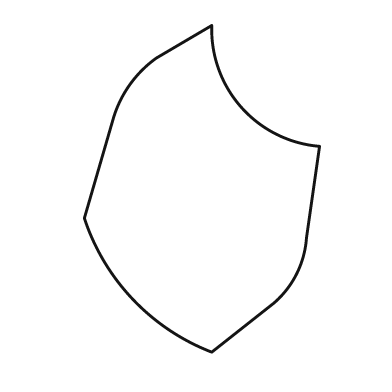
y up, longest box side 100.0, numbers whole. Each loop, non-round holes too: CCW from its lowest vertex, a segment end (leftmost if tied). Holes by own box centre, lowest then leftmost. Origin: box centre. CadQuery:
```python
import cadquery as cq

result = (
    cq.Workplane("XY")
    .moveTo(3.0, -50.0)
    .lineTo(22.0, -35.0)
    .threePointArc((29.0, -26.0), (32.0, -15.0))
    .lineTo(36.0, 13.0)
    .threePointArc((12.0, 25.0), (3.0, 50.0))
    .lineTo(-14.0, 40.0)
    .threePointArc((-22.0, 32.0), (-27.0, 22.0))
    .lineTo(-36.0, -9.0)
    .threePointArc((-21.0, -34.0), (3.0, -50.0))
    .close()
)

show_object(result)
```